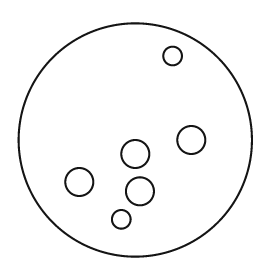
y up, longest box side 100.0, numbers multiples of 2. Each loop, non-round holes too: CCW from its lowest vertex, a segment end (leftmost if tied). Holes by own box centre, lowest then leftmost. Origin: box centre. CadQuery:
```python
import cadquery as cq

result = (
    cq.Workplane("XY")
    .moveTo(0.0, 0.0)
    .circle(50.0)
    .moveTo(-6.0, -34.0)
    .circle(4.0)
    .moveTo(2.0, -22.0)
    .circle(6.0)
    .moveTo(-24.0, -18.0)
    .circle(6.0)
    .moveTo(0.0, -6.0)
    .circle(6.0)
    .moveTo(24.0, 0.0)
    .circle(6.0)
    .moveTo(16.0, 36.0)
    .circle(4.0)
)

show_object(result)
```